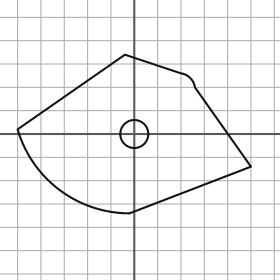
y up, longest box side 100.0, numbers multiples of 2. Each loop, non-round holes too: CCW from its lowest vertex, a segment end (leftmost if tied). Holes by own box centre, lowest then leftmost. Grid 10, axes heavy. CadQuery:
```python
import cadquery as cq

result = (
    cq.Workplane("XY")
    .moveTo(-2.0, -34.0)
    .lineTo(50.0, -14.0)
    .lineTo(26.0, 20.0)
    .threePointArc((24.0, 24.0), (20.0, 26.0))
    .lineTo(-4.0, 34.0)
    .lineTo(-50.0, 2.0)
    .threePointArc((-32.0, -24.0), (-2.0, -34.0))
    .close()
    .moveTo(0.0, 0.0)
    .circle(6.0)
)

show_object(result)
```